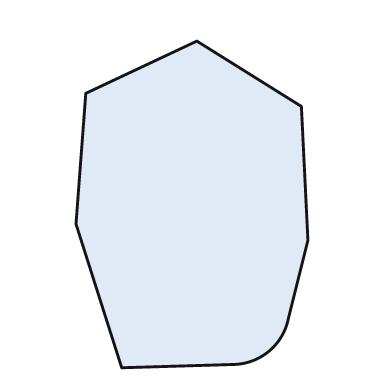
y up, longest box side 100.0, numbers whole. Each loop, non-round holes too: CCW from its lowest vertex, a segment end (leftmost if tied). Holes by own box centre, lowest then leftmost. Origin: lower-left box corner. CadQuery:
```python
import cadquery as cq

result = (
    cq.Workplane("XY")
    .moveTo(14.0, 0.0)
    .lineTo(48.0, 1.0)
    .threePointArc((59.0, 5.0), (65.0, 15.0))
    .lineTo(71.0, 39.0)
    .lineTo(69.0, 80.0)
    .lineTo(37.0, 100.0)
    .lineTo(3.0, 84.0)
    .lineTo(0.0, 44.0)
    .close()
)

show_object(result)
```